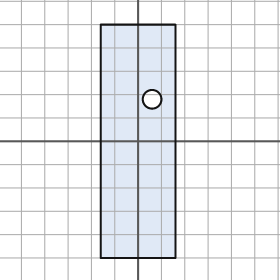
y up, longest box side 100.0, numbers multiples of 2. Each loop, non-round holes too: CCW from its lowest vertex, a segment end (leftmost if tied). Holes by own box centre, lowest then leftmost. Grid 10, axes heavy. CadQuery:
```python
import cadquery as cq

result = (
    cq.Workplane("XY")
    .moveTo(-16.0, -50.0)
    .lineTo(16.0, -50.0)
    .lineTo(16.0, 50.0)
    .lineTo(-16.0, 50.0)
    .close()
    .moveTo(6.0, 18.0)
    .circle(4.0)
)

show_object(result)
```